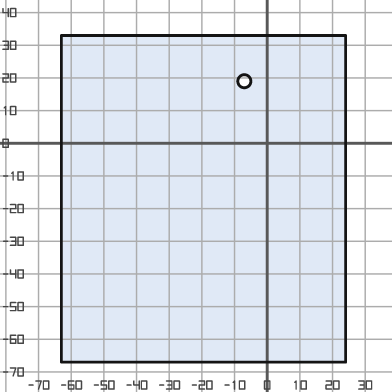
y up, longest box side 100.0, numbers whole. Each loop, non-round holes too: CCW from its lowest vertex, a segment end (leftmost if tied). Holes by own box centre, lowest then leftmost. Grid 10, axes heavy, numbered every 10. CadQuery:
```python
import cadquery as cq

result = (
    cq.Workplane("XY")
    .moveTo(-63.0, -67.0)
    .lineTo(24.0, -67.0)
    .lineTo(24.0, 33.0)
    .lineTo(-63.0, 33.0)
    .close()
    .moveTo(-7.0, 19.0)
    .circle(2.0)
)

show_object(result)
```